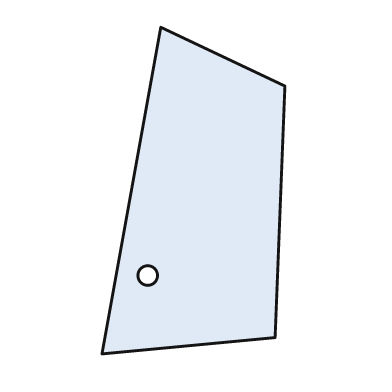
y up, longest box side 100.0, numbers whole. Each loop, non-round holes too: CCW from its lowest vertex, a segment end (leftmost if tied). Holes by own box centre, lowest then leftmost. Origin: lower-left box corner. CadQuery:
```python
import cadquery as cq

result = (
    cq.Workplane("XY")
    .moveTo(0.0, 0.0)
    .lineTo(53.0, 5.0)
    .lineTo(56.0, 82.0)
    .lineTo(18.0, 100.0)
    .close()
    .moveTo(14.0, 24.0)
    .circle(3.0)
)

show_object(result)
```